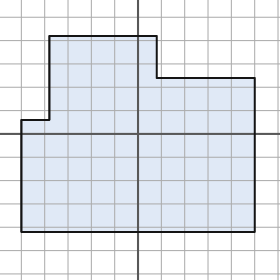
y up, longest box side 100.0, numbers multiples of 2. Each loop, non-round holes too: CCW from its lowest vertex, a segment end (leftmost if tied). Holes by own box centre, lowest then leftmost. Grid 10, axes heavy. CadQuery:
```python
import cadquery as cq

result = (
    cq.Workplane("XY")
    .moveTo(-50.0, -42.0)
    .lineTo(50.0, -42.0)
    .lineTo(50.0, 24.0)
    .lineTo(8.0, 24.0)
    .lineTo(8.0, 42.0)
    .lineTo(-38.0, 42.0)
    .lineTo(-38.0, 6.0)
    .lineTo(-50.0, 6.0)
    .close()
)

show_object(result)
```